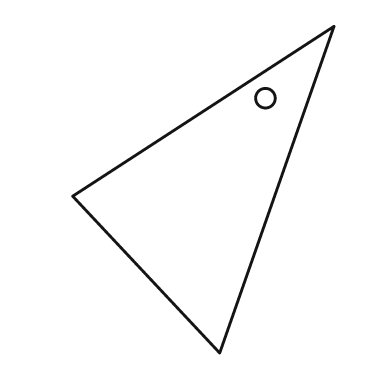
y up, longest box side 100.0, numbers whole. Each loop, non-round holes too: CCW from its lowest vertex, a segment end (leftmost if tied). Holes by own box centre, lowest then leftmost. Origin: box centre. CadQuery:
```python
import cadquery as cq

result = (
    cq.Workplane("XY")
    .moveTo(5.0, -50.0)
    .lineTo(40.0, 50.0)
    .lineTo(-40.0, -2.0)
    .close()
    .moveTo(19.0, 28.0)
    .circle(3.0)
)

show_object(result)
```